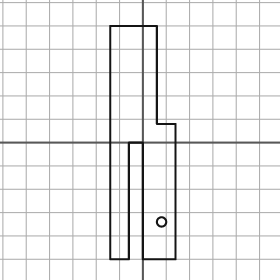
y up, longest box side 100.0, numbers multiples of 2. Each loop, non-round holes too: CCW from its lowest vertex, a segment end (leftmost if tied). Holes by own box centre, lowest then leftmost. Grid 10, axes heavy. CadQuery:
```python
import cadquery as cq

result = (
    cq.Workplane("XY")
    .moveTo(-14.0, -50.0)
    .lineTo(-6.0, -50.0)
    .lineTo(-6.0, 0.0)
    .lineTo(0.0, 0.0)
    .lineTo(0.0, -50.0)
    .lineTo(14.0, -50.0)
    .lineTo(14.0, 8.0)
    .lineTo(6.0, 8.0)
    .lineTo(6.0, 50.0)
    .lineTo(-14.0, 50.0)
    .close()
    .moveTo(8.0, -34.0)
    .circle(2.0)
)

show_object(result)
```